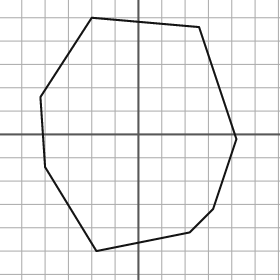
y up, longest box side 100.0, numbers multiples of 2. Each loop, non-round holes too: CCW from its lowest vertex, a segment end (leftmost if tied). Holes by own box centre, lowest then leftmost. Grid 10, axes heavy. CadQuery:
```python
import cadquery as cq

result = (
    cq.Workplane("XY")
    .moveTo(-18.0, -50.0)
    .lineTo(22.0, -42.0)
    .lineTo(32.0, -32.0)
    .lineTo(42.0, -2.0)
    .lineTo(26.0, 46.0)
    .lineTo(-20.0, 50.0)
    .lineTo(-42.0, 16.0)
    .lineTo(-40.0, -14.0)
    .close()
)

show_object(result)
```